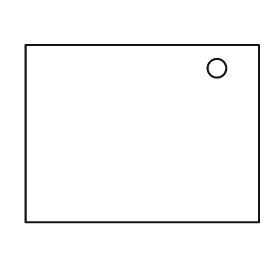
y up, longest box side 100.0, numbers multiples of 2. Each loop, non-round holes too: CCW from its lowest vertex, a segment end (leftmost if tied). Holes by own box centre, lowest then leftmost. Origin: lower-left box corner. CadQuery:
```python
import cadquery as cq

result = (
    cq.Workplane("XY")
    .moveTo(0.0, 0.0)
    .lineTo(100.0, 0.0)
    .lineTo(100.0, 76.0)
    .lineTo(0.0, 76.0)
    .close()
    .moveTo(82.0, 66.0)
    .circle(4.0)
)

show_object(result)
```